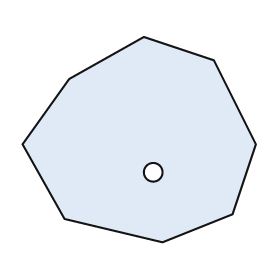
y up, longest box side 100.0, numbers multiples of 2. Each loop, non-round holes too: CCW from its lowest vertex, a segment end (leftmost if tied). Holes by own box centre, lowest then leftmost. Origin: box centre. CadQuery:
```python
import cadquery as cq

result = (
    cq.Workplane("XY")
    .moveTo(10.0, -44.0)
    .lineTo(40.0, -32.0)
    .lineTo(50.0, -2.0)
    .lineTo(32.0, 34.0)
    .lineTo(2.0, 44.0)
    .lineTo(-30.0, 26.0)
    .lineTo(-50.0, -2.0)
    .lineTo(-32.0, -34.0)
    .close()
    .moveTo(6.0, -14.0)
    .circle(4.0)
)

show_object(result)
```